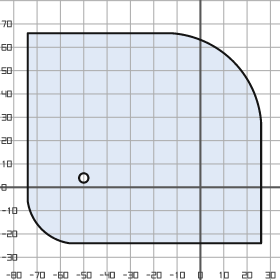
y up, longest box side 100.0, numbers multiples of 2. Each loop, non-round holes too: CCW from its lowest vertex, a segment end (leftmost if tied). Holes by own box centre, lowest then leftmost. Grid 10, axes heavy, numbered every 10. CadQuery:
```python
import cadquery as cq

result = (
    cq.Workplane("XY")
    .moveTo(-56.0, -24.0)
    .lineTo(26.0, -24.0)
    .lineTo(26.0, 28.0)
    .threePointArc((14.0, 54.0), (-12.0, 66.0))
    .lineTo(-74.0, 66.0)
    .lineTo(-74.0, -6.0)
    .threePointArc((-68.0, -18.0), (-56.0, -24.0))
    .close()
    .moveTo(-50.0, 4.0)
    .circle(2.0)
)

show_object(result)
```